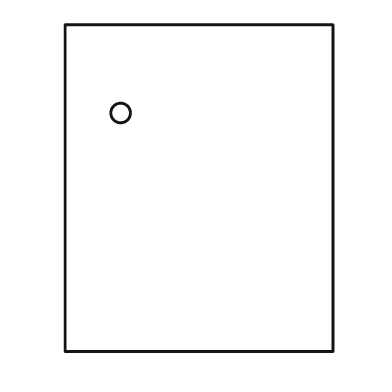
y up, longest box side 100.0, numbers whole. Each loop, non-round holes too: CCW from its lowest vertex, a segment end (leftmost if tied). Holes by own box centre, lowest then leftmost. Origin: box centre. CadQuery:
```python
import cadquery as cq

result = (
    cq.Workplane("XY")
    .moveTo(-41.0, -50.0)
    .lineTo(41.0, -50.0)
    .lineTo(41.0, 50.0)
    .lineTo(-41.0, 50.0)
    .close()
    .moveTo(-24.0, 23.0)
    .circle(3.0)
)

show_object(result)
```